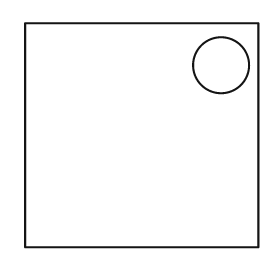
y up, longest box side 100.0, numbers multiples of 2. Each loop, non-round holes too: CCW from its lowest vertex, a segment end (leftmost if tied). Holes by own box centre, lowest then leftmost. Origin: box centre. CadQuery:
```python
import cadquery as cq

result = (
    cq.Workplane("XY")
    .moveTo(-50.0, -48.0)
    .lineTo(50.0, -48.0)
    .lineTo(50.0, 48.0)
    .lineTo(-50.0, 48.0)
    .close()
    .moveTo(34.0, 30.0)
    .circle(12.0)
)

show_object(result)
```